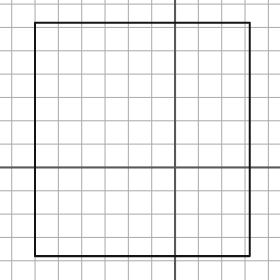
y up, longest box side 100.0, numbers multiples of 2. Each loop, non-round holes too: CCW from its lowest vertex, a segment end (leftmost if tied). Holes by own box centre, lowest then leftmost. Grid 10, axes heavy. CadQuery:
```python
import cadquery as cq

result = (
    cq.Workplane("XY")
    .moveTo(-60.0, -38.0)
    .lineTo(32.0, -38.0)
    .lineTo(32.0, 62.0)
    .lineTo(-60.0, 62.0)
    .close()
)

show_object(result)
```